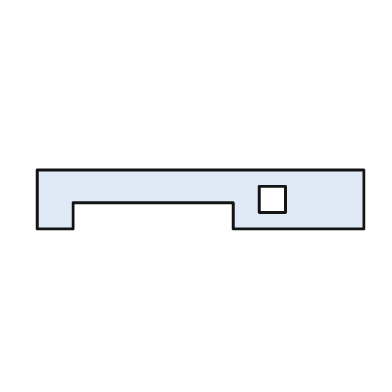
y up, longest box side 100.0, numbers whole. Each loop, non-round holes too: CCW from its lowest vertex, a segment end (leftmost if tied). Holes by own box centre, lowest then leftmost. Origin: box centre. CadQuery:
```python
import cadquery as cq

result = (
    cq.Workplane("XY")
    .moveTo(-50.0, -9.0)
    .lineTo(-39.0, -9.0)
    .lineTo(-39.0, -1.0)
    .lineTo(10.0, -1.0)
    .lineTo(10.0, -9.0)
    .lineTo(50.0, -9.0)
    .lineTo(50.0, 9.0)
    .lineTo(-50.0, 9.0)
    .close()
    .moveTo(18.0, -4.0)
    .lineTo(26.0, -4.0)
    .lineTo(26.0, 4.0)
    .lineTo(18.0, 4.0)
    .close()
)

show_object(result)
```